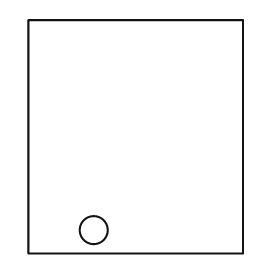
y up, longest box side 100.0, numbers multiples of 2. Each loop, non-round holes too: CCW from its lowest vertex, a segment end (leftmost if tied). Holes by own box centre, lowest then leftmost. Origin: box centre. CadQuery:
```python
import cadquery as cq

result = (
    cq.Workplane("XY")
    .moveTo(-46.0, -50.0)
    .lineTo(46.0, -50.0)
    .lineTo(46.0, 50.0)
    .lineTo(-46.0, 50.0)
    .close()
    .moveTo(-18.0, -40.0)
    .circle(6.0)
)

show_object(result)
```